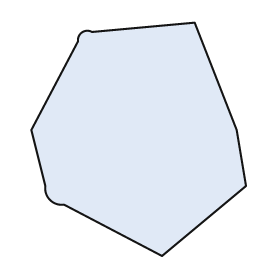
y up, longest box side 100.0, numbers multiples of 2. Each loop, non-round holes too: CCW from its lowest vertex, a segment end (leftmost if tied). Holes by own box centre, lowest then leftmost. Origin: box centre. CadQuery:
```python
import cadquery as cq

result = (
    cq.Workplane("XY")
    .moveTo(10.0, -50.0)
    .lineTo(46.0, -20.0)
    .lineTo(42.0, 4.0)
    .lineTo(24.0, 50.0)
    .lineTo(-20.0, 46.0)
    .threePointArc((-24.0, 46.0), (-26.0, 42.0))
    .lineTo(-46.0, 4.0)
    .lineTo(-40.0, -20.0)
    .threePointArc((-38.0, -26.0), (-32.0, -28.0))
    .close()
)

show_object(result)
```